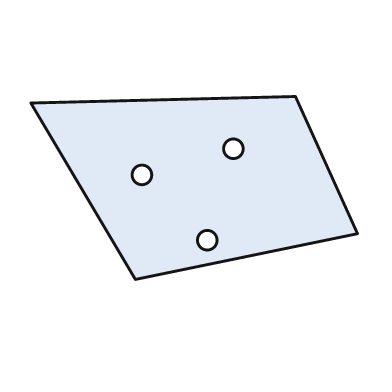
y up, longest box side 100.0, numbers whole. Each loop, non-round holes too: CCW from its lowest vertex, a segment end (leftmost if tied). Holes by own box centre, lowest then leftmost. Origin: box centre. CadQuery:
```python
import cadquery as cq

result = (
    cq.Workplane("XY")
    .moveTo(-18.0, -28.0)
    .lineTo(50.0, -14.0)
    .lineTo(31.0, 28.0)
    .lineTo(-50.0, 26.0)
    .close()
    .moveTo(4.0, -16.0)
    .circle(3.0)
    .moveTo(-16.0, 4.0)
    .circle(3.0)
    .moveTo(12.0, 12.0)
    .circle(3.0)
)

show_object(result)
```